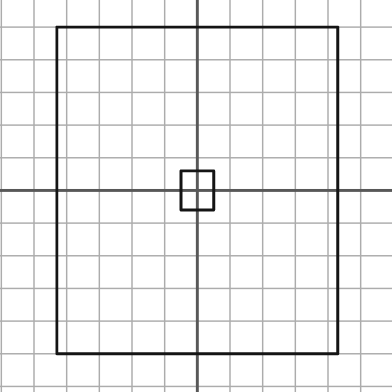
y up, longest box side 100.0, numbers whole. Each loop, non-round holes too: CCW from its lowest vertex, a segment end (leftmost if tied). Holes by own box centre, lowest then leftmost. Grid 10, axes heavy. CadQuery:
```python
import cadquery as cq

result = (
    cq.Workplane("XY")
    .moveTo(-43.0, -50.0)
    .lineTo(43.0, -50.0)
    .lineTo(43.0, 50.0)
    .lineTo(-43.0, 50.0)
    .close()
    .moveTo(-5.0, -6.0)
    .lineTo(5.0, -6.0)
    .lineTo(5.0, 6.0)
    .lineTo(-5.0, 6.0)
    .close()
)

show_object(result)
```